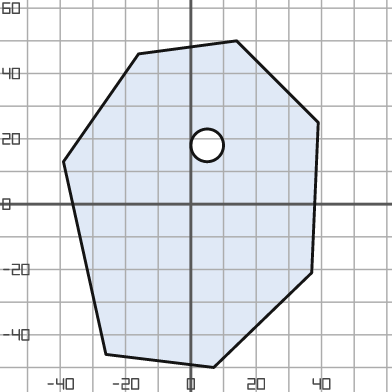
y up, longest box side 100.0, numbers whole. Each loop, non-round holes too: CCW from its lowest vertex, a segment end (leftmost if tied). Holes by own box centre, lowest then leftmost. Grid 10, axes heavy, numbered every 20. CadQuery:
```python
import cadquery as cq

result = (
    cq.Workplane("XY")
    .moveTo(7.0, -50.0)
    .lineTo(37.0, -21.0)
    .lineTo(39.0, 25.0)
    .lineTo(14.0, 50.0)
    .lineTo(-16.0, 46.0)
    .lineTo(-39.0, 13.0)
    .lineTo(-26.0, -46.0)
    .close()
    .moveTo(5.0, 18.0)
    .circle(5.0)
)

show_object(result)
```